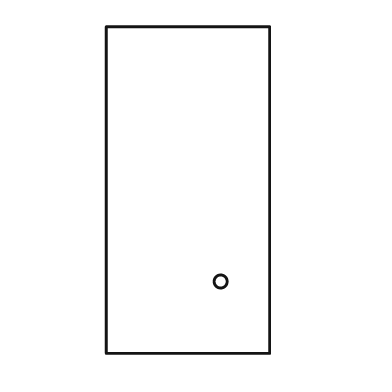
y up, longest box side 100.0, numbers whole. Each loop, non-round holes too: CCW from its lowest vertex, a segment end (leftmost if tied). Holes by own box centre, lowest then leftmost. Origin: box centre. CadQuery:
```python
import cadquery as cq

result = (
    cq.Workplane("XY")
    .moveTo(-25.0, -50.0)
    .lineTo(25.0, -50.0)
    .lineTo(25.0, 50.0)
    .lineTo(-25.0, 50.0)
    .close()
    .moveTo(10.0, -28.0)
    .circle(2.0)
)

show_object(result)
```